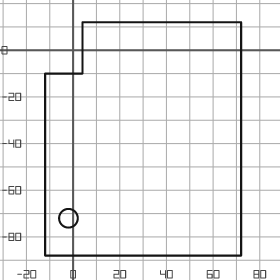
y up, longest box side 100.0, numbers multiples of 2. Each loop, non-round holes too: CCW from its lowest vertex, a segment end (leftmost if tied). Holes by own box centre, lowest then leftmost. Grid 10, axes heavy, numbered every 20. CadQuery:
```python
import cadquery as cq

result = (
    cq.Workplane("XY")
    .moveTo(-12.0, -88.0)
    .lineTo(72.0, -88.0)
    .lineTo(72.0, 12.0)
    .lineTo(4.0, 12.0)
    .lineTo(4.0, -10.0)
    .lineTo(-12.0, -10.0)
    .close()
    .moveTo(-2.0, -72.0)
    .circle(4.0)
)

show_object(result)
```